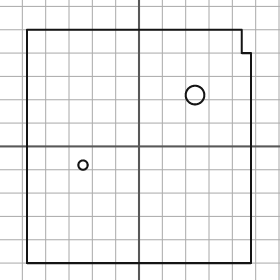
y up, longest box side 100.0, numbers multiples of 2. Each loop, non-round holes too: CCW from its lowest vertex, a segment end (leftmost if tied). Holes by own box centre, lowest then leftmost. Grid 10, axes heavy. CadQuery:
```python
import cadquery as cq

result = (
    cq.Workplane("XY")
    .moveTo(-48.0, -50.0)
    .lineTo(48.0, -50.0)
    .lineTo(48.0, 40.0)
    .lineTo(44.0, 40.0)
    .lineTo(44.0, 50.0)
    .lineTo(-48.0, 50.0)
    .close()
    .moveTo(-24.0, -8.0)
    .circle(2.0)
    .moveTo(24.0, 22.0)
    .circle(4.0)
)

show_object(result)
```